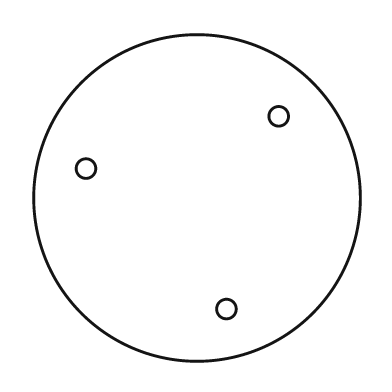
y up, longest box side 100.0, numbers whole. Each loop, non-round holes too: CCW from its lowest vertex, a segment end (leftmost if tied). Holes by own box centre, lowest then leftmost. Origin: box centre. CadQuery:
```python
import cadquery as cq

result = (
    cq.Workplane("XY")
    .moveTo(0.0, 0.0)
    .circle(50.0)
    .moveTo(9.0, -34.0)
    .circle(3.0)
    .moveTo(-34.0, 9.0)
    .circle(3.0)
    .moveTo(25.0, 25.0)
    .circle(3.0)
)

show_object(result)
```